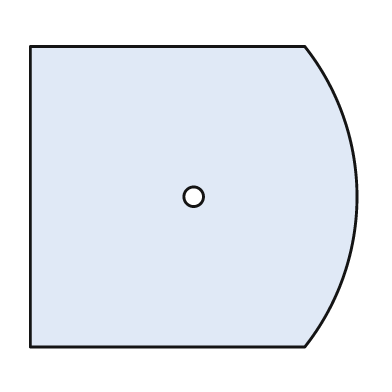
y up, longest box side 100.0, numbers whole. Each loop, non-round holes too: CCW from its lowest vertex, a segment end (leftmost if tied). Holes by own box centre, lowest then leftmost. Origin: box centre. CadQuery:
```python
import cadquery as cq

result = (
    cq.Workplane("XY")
    .moveTo(-50.0, -46.0)
    .lineTo(34.0, -46.0)
    .threePointArc((50.0, 0.0), (34.0, 46.0))
    .lineTo(-50.0, 46.0)
    .close()
    .moveTo(0.0, 0.0)
    .circle(3.0)
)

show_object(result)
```